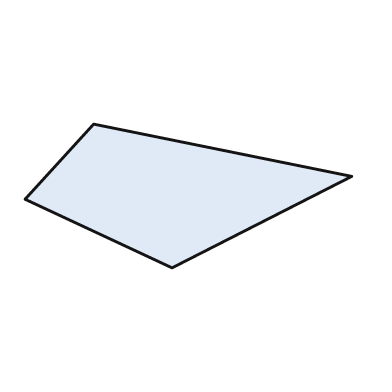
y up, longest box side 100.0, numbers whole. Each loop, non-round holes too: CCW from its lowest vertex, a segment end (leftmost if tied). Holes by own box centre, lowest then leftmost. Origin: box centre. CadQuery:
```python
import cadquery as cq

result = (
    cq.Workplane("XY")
    .moveTo(-5.0, -22.0)
    .lineTo(50.0, 6.0)
    .lineTo(-29.0, 22.0)
    .lineTo(-50.0, -1.0)
    .close()
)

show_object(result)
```